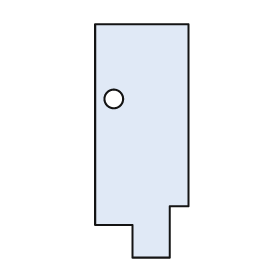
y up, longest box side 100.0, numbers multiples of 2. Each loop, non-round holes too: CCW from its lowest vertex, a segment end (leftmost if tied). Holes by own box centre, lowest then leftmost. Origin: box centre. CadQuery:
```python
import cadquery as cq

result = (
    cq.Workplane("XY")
    .moveTo(-4.0, -50.0)
    .lineTo(12.0, -50.0)
    .lineTo(12.0, -28.0)
    .lineTo(20.0, -28.0)
    .lineTo(20.0, 50.0)
    .lineTo(-20.0, 50.0)
    .lineTo(-20.0, -36.0)
    .lineTo(-4.0, -36.0)
    .close()
    .moveTo(-12.0, 18.0)
    .circle(4.0)
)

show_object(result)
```